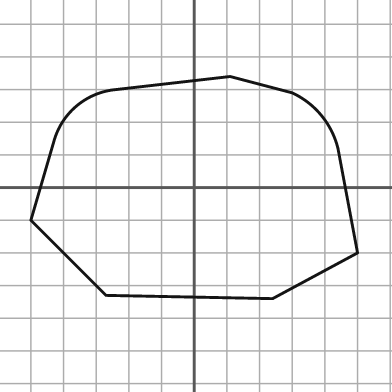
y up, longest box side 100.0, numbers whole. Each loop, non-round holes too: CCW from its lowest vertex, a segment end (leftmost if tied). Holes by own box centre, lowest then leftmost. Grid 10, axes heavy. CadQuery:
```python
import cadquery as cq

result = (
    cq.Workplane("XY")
    .moveTo(24.0, -34.0)
    .lineTo(50.0, -20.0)
    .lineTo(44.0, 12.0)
    .threePointArc((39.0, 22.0), (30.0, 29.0))
    .lineTo(11.0, 34.0)
    .lineTo(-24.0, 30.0)
    .threePointArc((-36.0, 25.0), (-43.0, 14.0))
    .lineTo(-50.0, -10.0)
    .lineTo(-27.0, -33.0)
    .close()
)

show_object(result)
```